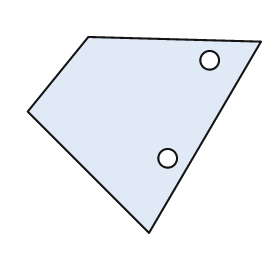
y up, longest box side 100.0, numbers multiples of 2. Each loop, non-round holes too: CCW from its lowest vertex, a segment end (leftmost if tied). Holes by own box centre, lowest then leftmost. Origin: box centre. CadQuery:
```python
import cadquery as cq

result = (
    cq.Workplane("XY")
    .moveTo(2.0, -42.0)
    .lineTo(50.0, 40.0)
    .lineTo(-24.0, 42.0)
    .lineTo(-50.0, 10.0)
    .close()
    .moveTo(10.0, -10.0)
    .circle(4.0)
    .moveTo(28.0, 32.0)
    .circle(4.0)
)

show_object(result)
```